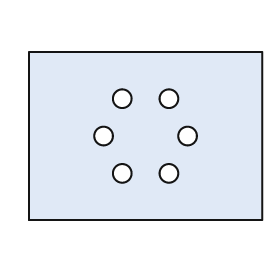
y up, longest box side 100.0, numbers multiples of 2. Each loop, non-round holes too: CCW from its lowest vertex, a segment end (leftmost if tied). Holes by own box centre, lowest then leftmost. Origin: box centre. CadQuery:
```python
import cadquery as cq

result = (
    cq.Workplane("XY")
    .moveTo(-50.0, -36.0)
    .lineTo(50.0, -36.0)
    .lineTo(50.0, 36.0)
    .lineTo(-50.0, 36.0)
    .close()
    .moveTo(-10.0, -16.0)
    .circle(4.0)
    .moveTo(10.0, -16.0)
    .circle(4.0)
    .moveTo(-18.0, 0.0)
    .circle(4.0)
    .moveTo(18.0, 0.0)
    .circle(4.0)
    .moveTo(-10.0, 16.0)
    .circle(4.0)
    .moveTo(10.0, 16.0)
    .circle(4.0)
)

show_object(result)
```